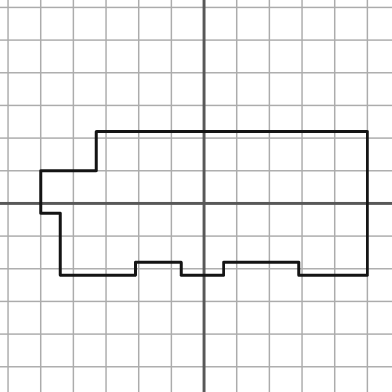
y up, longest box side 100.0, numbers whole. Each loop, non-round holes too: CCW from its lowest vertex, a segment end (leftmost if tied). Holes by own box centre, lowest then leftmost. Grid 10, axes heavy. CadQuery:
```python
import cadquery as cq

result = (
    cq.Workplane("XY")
    .moveTo(-44.0, -22.0)
    .lineTo(-21.0, -22.0)
    .lineTo(-21.0, -18.0)
    .lineTo(-7.0, -18.0)
    .lineTo(-7.0, -22.0)
    .lineTo(6.0, -22.0)
    .lineTo(6.0, -18.0)
    .lineTo(29.0, -18.0)
    .lineTo(29.0, -22.0)
    .lineTo(50.0, -22.0)
    .lineTo(50.0, 22.0)
    .lineTo(-33.0, 22.0)
    .lineTo(-33.0, 10.0)
    .lineTo(-50.0, 10.0)
    .lineTo(-50.0, -3.0)
    .lineTo(-44.0, -3.0)
    .close()
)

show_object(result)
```